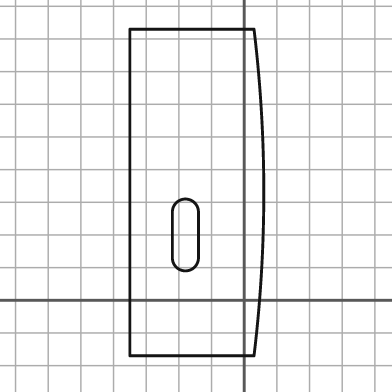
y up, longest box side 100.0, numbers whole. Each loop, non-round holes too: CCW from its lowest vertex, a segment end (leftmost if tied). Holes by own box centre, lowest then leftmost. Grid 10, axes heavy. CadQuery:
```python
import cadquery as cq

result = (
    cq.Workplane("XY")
    .moveTo(-35.0, -17.0)
    .lineTo(3.0, -17.0)
    .threePointArc((6.0, 33.0), (3.0, 83.0))
    .lineTo(-35.0, 83.0)
    .close()
    .moveTo(-22.0, 13.0)
    .threePointArc((-18.0, 9.0), (-14.0, 13.0))
    .lineTo(-14.0, 27.0)
    .threePointArc((-18.0, 31.0), (-22.0, 27.0))
    .close()
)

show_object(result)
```